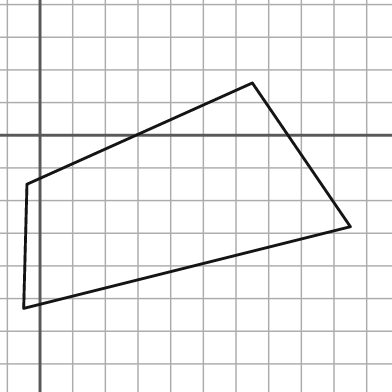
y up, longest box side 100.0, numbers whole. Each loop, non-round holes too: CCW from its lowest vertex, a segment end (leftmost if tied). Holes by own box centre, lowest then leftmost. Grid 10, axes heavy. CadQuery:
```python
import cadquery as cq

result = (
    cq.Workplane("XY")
    .moveTo(-5.0, -53.0)
    .lineTo(95.0, -28.0)
    .lineTo(65.0, 16.0)
    .lineTo(-4.0, -15.0)
    .close()
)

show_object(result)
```